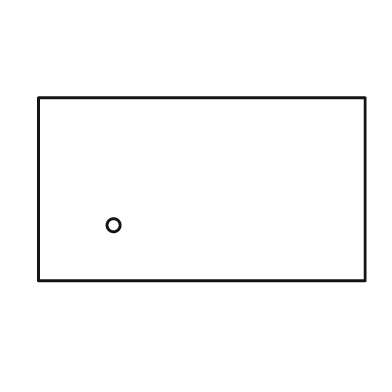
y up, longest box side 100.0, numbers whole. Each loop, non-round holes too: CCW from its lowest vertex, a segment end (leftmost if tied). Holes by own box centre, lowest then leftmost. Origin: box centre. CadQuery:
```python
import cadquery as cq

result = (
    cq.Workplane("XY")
    .moveTo(-50.0, -28.0)
    .lineTo(50.0, -28.0)
    .lineTo(50.0, 28.0)
    .lineTo(-50.0, 28.0)
    .close()
    .moveTo(-27.0, -11.0)
    .circle(2.0)
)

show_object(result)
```